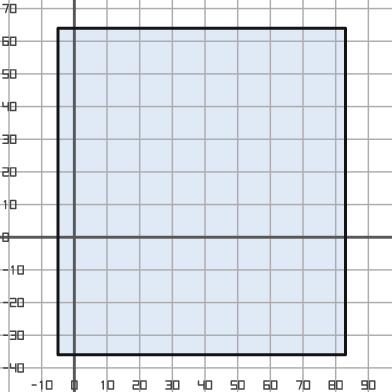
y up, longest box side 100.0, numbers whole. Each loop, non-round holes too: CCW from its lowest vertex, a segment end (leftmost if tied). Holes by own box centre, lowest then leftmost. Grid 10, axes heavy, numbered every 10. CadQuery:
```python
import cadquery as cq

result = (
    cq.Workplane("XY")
    .moveTo(-5.0, -36.0)
    .lineTo(83.0, -36.0)
    .lineTo(83.0, 64.0)
    .lineTo(-5.0, 64.0)
    .close()
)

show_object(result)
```